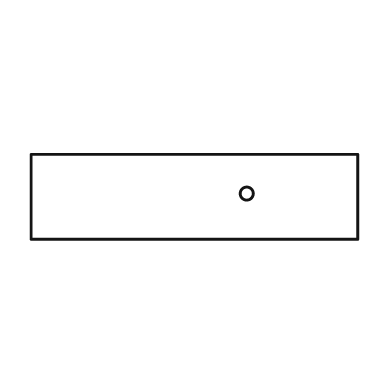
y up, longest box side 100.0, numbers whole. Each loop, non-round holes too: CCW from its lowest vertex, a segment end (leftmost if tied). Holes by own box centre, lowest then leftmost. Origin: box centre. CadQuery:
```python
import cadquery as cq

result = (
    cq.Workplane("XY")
    .moveTo(-50.0, -13.0)
    .lineTo(50.0, -13.0)
    .lineTo(50.0, 13.0)
    .lineTo(-50.0, 13.0)
    .close()
    .moveTo(16.0, 1.0)
    .circle(2.0)
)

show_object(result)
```